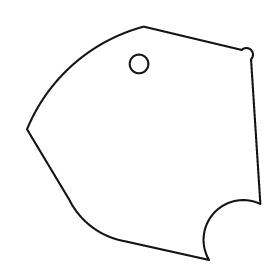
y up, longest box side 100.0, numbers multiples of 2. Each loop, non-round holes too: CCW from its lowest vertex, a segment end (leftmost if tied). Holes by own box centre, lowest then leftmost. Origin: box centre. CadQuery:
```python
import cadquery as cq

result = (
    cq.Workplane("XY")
    .moveTo(28.0, -50.0)
    .threePointArc((30.0, -30.0), (50.0, -26.0))
    .lineTo(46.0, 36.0)
    .threePointArc((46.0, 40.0), (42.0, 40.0))
    .lineTo(0.0, 50.0)
    .threePointArc((-30.0, 34.0), (-50.0, 6.0))
    .lineTo(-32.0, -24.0)
    .threePointArc((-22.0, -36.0), (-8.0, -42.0))
    .close()
    .moveTo(-2.0, 34.0)
    .circle(4.0)
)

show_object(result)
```